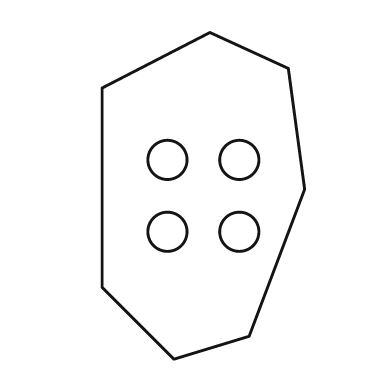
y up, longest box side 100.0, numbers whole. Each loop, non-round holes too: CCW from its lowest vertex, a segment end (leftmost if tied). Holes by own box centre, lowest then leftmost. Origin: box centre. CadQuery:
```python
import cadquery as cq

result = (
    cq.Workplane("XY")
    .moveTo(-9.0, -50.0)
    .lineTo(14.0, -43.0)
    .lineTo(31.0, 2.0)
    .lineTo(26.0, 39.0)
    .lineTo(2.0, 50.0)
    .lineTo(-31.0, 33.0)
    .lineTo(-31.0, -28.0)
    .close()
    .moveTo(-11.0, -11.0)
    .circle(6.0)
    .moveTo(11.0, -11.0)
    .circle(6.0)
    .moveTo(-11.0, 11.0)
    .circle(6.0)
    .moveTo(11.0, 11.0)
    .circle(6.0)
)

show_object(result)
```